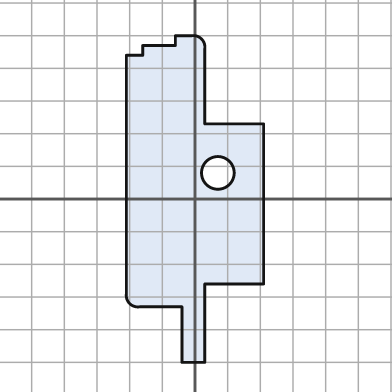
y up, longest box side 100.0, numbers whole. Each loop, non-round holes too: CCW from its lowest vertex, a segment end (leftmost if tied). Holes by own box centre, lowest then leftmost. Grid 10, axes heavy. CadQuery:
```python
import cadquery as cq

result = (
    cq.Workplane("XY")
    .moveTo(-4.0, -50.0)
    .lineTo(3.0, -50.0)
    .lineTo(3.0, -26.0)
    .lineTo(21.0, -26.0)
    .lineTo(21.0, 23.0)
    .lineTo(3.0, 23.0)
    .lineTo(3.0, 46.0)
    .threePointArc((2.0, 49.0), (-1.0, 50.0))
    .lineTo(-6.0, 50.0)
    .lineTo(-6.0, 47.0)
    .lineTo(-16.0, 47.0)
    .lineTo(-16.0, 44.0)
    .lineTo(-21.0, 44.0)
    .lineTo(-21.0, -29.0)
    .threePointArc((-20.0, -32.0), (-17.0, -33.0))
    .lineTo(-4.0, -33.0)
    .close()
    .moveTo(7.0, 8.0)
    .circle(5.0)
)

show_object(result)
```